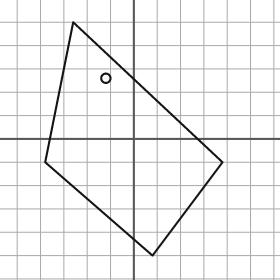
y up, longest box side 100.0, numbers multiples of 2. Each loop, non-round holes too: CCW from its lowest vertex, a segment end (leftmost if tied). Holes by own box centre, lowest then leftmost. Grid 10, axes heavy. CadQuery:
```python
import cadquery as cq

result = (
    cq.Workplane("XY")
    .moveTo(8.0, -50.0)
    .lineTo(38.0, -10.0)
    .lineTo(-26.0, 50.0)
    .lineTo(-38.0, -10.0)
    .close()
    .moveTo(-12.0, 26.0)
    .circle(2.0)
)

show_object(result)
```